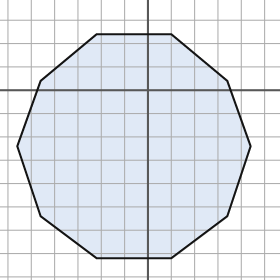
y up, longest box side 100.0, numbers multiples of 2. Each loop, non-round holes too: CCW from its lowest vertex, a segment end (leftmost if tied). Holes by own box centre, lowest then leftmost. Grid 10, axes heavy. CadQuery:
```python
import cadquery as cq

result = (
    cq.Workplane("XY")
    .moveTo(-22.0, -72.0)
    .lineTo(10.0, -72.0)
    .lineTo(34.0, -54.0)
    .lineTo(44.0, -24.0)
    .lineTo(34.0, 4.0)
    .lineTo(10.0, 24.0)
    .lineTo(-22.0, 24.0)
    .lineTo(-46.0, 4.0)
    .lineTo(-56.0, -24.0)
    .lineTo(-46.0, -54.0)
    .close()
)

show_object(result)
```